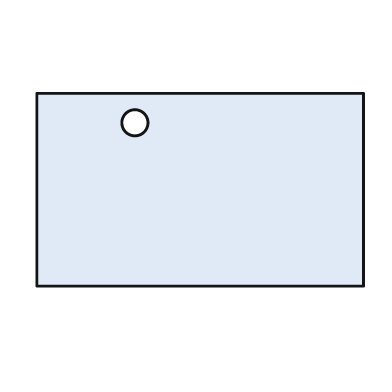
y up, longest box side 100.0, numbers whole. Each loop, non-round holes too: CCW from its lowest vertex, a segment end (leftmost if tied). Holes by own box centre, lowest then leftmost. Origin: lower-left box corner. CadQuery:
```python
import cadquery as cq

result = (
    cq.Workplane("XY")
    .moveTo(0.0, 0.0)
    .lineTo(100.0, 0.0)
    .lineTo(100.0, 59.0)
    .lineTo(0.0, 59.0)
    .close()
    .moveTo(30.0, 50.0)
    .circle(4.0)
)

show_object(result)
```